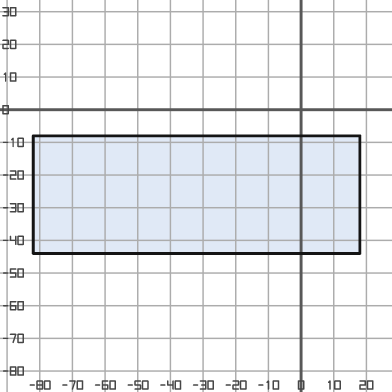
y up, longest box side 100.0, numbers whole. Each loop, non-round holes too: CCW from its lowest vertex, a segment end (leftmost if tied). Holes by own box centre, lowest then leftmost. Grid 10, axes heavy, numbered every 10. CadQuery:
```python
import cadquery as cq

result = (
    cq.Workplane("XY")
    .moveTo(-82.0, -44.0)
    .lineTo(18.0, -44.0)
    .lineTo(18.0, -8.0)
    .lineTo(-82.0, -8.0)
    .close()
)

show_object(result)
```